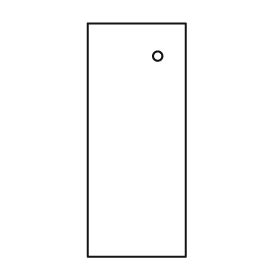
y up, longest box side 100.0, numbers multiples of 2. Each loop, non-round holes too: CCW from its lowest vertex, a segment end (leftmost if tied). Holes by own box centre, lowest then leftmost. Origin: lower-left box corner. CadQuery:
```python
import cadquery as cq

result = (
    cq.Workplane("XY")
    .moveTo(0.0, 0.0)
    .lineTo(42.0, 0.0)
    .lineTo(42.0, 100.0)
    .lineTo(0.0, 100.0)
    .close()
    .moveTo(30.0, 86.0)
    .circle(2.0)
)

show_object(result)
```